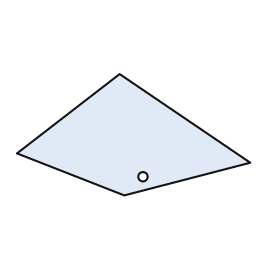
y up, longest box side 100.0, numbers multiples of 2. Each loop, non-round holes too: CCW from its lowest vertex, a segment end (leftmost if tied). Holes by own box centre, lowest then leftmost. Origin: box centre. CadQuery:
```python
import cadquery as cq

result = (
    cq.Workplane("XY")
    .moveTo(-4.0, -26.0)
    .lineTo(50.0, -12.0)
    .lineTo(-6.0, 26.0)
    .lineTo(-50.0, -8.0)
    .close()
    .moveTo(4.0, -18.0)
    .circle(2.0)
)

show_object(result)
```